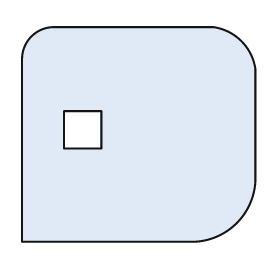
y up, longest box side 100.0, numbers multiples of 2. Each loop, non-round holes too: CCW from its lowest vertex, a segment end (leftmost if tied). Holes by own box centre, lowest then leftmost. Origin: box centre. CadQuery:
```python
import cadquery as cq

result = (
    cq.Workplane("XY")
    .moveTo(-50.0, -46.0)
    .lineTo(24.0, -46.0)
    .threePointArc((42.0, -38.0), (50.0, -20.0))
    .lineTo(50.0, 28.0)
    .threePointArc((44.0, 40.0), (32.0, 46.0))
    .lineTo(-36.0, 46.0)
    .threePointArc((-46.0, 42.0), (-50.0, 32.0))
    .close()
    .moveTo(-32.0, -6.0)
    .lineTo(-16.0, -6.0)
    .lineTo(-16.0, 10.0)
    .lineTo(-32.0, 10.0)
    .close()
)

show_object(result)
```